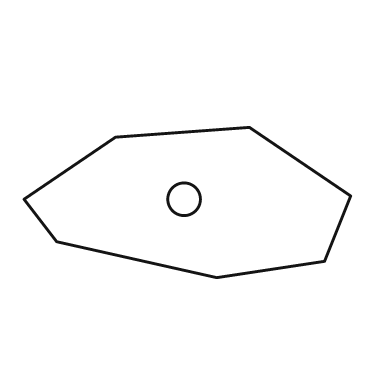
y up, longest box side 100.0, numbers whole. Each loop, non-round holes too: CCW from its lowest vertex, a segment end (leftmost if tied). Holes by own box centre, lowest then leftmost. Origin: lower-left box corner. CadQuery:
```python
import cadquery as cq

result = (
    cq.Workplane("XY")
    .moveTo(59.0, 0.0)
    .lineTo(92.0, 5.0)
    .lineTo(100.0, 25.0)
    .lineTo(69.0, 46.0)
    .lineTo(28.0, 43.0)
    .lineTo(0.0, 24.0)
    .lineTo(10.0, 11.0)
    .close()
    .moveTo(49.0, 24.0)
    .circle(5.0)
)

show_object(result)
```